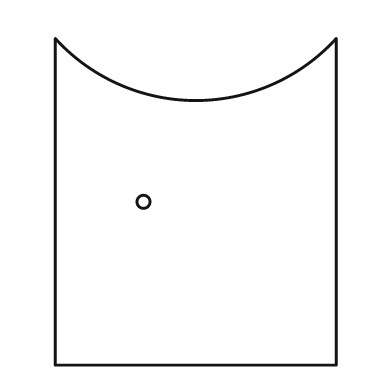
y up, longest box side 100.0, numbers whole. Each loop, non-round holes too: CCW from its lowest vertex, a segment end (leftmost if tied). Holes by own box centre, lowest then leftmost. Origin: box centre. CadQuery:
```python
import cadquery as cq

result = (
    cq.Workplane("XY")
    .moveTo(-43.0, -50.0)
    .lineTo(43.0, -50.0)
    .lineTo(43.0, 50.0)
    .threePointArc((0.0, 31.0), (-43.0, 50.0))
    .close()
    .moveTo(-16.0, 0.0)
    .circle(2.0)
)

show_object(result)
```